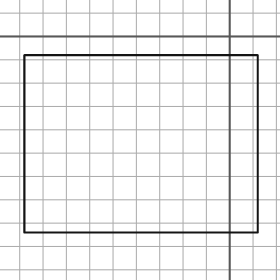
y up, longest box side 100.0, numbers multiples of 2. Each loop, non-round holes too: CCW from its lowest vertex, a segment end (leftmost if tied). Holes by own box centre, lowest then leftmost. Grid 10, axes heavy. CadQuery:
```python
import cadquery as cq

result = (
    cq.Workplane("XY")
    .moveTo(-88.0, -84.0)
    .lineTo(12.0, -84.0)
    .lineTo(12.0, -8.0)
    .lineTo(-88.0, -8.0)
    .close()
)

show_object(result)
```